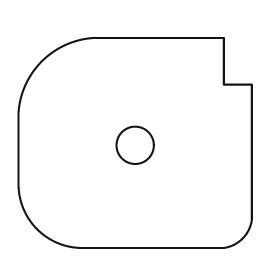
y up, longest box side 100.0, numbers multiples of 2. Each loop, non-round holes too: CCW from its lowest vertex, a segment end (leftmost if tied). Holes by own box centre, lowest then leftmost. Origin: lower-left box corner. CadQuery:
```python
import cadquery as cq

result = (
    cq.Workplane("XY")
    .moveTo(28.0, 0.0)
    .lineTo(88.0, 0.0)
    .threePointArc((96.0, 4.0), (100.0, 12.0))
    .lineTo(100.0, 70.0)
    .lineTo(88.0, 70.0)
    .lineTo(88.0, 90.0)
    .lineTo(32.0, 90.0)
    .threePointArc((10.0, 80.0), (0.0, 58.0))
    .lineTo(0.0, 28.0)
    .threePointArc((8.0, 8.0), (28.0, 0.0))
    .close()
    .moveTo(50.0, 44.0)
    .circle(8.0)
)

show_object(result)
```